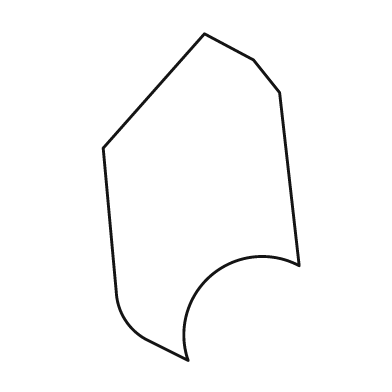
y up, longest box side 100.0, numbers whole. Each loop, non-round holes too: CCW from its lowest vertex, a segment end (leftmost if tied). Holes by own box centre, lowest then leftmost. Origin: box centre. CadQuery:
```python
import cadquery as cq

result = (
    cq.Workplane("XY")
    .moveTo(-4.0, -50.0)
    .threePointArc((3.0, -24.0), (30.0, -21.0))
    .lineTo(24.0, 32.0)
    .lineTo(16.0, 42.0)
    .lineTo(1.0, 50.0)
    .lineTo(-30.0, 15.0)
    .lineTo(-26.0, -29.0)
    .threePointArc((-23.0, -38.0), (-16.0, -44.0))
    .close()
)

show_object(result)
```